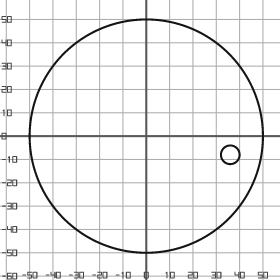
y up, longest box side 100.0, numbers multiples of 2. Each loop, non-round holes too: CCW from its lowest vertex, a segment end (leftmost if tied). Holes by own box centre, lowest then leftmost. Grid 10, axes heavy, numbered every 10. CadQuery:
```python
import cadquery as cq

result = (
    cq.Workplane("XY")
    .moveTo(0.0, 0.0)
    .circle(50.0)
    .moveTo(36.0, -8.0)
    .circle(4.0)
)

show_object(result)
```